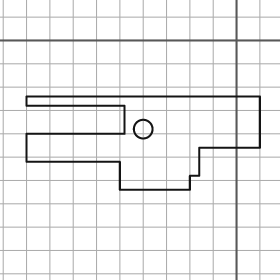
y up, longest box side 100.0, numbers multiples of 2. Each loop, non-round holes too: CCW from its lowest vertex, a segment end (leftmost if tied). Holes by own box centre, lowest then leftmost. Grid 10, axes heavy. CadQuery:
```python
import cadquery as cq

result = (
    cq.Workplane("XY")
    .moveTo(-50.0, -64.0)
    .lineTo(-20.0, -64.0)
    .lineTo(-20.0, -58.0)
    .lineTo(-16.0, -58.0)
    .lineTo(-16.0, -46.0)
    .lineTo(10.0, -46.0)
    .lineTo(10.0, -24.0)
    .lineTo(-90.0, -24.0)
    .lineTo(-90.0, -28.0)
    .lineTo(-48.0, -28.0)
    .lineTo(-48.0, -40.0)
    .lineTo(-90.0, -40.0)
    .lineTo(-90.0, -52.0)
    .lineTo(-50.0, -52.0)
    .close()
    .moveTo(-40.0, -38.0)
    .circle(4.0)
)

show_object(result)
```